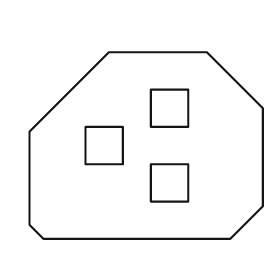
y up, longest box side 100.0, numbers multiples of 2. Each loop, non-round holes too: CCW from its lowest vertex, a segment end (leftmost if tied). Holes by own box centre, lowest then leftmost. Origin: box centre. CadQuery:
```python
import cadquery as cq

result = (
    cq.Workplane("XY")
    .moveTo(-44.0, -40.0)
    .lineTo(36.0, -40.0)
    .lineTo(50.0, -26.0)
    .lineTo(50.0, 16.0)
    .lineTo(26.0, 40.0)
    .lineTo(-16.0, 40.0)
    .lineTo(-50.0, 6.0)
    .lineTo(-50.0, -34.0)
    .close()
    .moveTo(2.0, -24.0)
    .lineTo(18.0, -24.0)
    .lineTo(18.0, -8.0)
    .lineTo(2.0, -8.0)
    .close()
    .moveTo(-26.0, -8.0)
    .lineTo(-10.0, -8.0)
    .lineTo(-10.0, 8.0)
    .lineTo(-26.0, 8.0)
    .close()
    .moveTo(2.0, 8.0)
    .lineTo(18.0, 8.0)
    .lineTo(18.0, 24.0)
    .lineTo(2.0, 24.0)
    .close()
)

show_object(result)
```